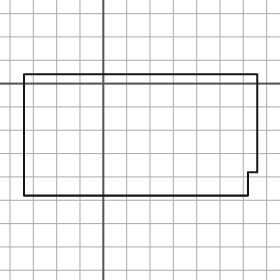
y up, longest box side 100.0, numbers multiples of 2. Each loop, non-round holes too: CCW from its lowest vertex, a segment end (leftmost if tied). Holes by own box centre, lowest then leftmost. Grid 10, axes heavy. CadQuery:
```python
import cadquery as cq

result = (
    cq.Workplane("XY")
    .moveTo(-34.0, -48.0)
    .lineTo(62.0, -48.0)
    .lineTo(62.0, -38.0)
    .lineTo(66.0, -38.0)
    .lineTo(66.0, 4.0)
    .lineTo(-34.0, 4.0)
    .close()
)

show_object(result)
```